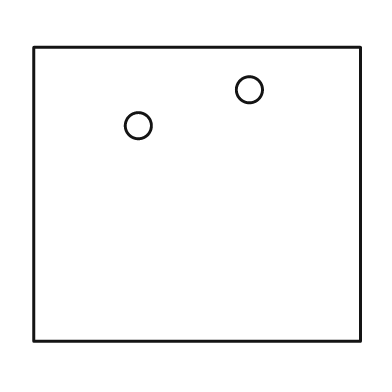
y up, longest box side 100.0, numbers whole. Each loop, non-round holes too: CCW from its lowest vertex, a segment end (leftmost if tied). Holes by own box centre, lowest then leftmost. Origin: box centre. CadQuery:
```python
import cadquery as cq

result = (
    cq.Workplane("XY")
    .moveTo(-50.0, -45.0)
    .lineTo(50.0, -45.0)
    .lineTo(50.0, 45.0)
    .lineTo(-50.0, 45.0)
    .close()
    .moveTo(-18.0, 21.0)
    .circle(4.0)
    .moveTo(16.0, 32.0)
    .circle(4.0)
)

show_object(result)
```